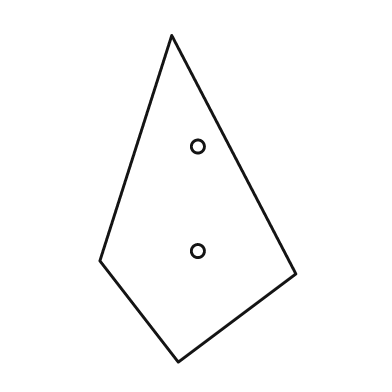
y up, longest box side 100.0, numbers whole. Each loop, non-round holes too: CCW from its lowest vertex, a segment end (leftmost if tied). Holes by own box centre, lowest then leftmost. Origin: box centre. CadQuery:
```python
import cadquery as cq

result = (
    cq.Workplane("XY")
    .moveTo(-6.0, -50.0)
    .lineTo(30.0, -23.0)
    .lineTo(-8.0, 50.0)
    .lineTo(-30.0, -19.0)
    .close()
    .moveTo(0.0, -16.0)
    .circle(2.0)
    .moveTo(0.0, 16.0)
    .circle(2.0)
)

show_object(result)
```